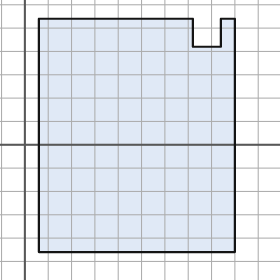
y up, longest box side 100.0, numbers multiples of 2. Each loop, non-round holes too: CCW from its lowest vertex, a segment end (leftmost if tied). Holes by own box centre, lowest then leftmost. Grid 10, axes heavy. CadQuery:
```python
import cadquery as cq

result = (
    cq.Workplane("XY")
    .moveTo(6.0, -46.0)
    .lineTo(90.0, -46.0)
    .lineTo(90.0, 54.0)
    .lineTo(84.0, 54.0)
    .lineTo(84.0, 42.0)
    .lineTo(72.0, 42.0)
    .lineTo(72.0, 54.0)
    .lineTo(6.0, 54.0)
    .close()
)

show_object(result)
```